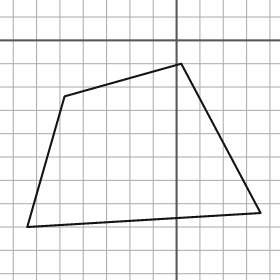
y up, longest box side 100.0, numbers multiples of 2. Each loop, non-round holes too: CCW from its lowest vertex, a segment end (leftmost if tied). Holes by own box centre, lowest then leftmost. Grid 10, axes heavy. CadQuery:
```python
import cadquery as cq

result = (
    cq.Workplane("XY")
    .moveTo(-64.0, -80.0)
    .lineTo(36.0, -74.0)
    .lineTo(2.0, -10.0)
    .lineTo(-48.0, -24.0)
    .close()
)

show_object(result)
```